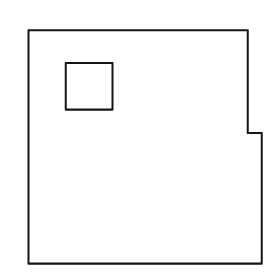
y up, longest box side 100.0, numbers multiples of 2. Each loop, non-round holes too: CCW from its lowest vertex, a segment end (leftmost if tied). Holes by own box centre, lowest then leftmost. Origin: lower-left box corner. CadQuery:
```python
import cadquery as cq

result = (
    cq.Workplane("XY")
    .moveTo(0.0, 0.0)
    .lineTo(100.0, 0.0)
    .lineTo(100.0, 56.0)
    .lineTo(94.0, 56.0)
    .lineTo(94.0, 100.0)
    .lineTo(0.0, 100.0)
    .close()
    .moveTo(16.0, 66.0)
    .lineTo(36.0, 66.0)
    .lineTo(36.0, 86.0)
    .lineTo(16.0, 86.0)
    .close()
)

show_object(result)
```